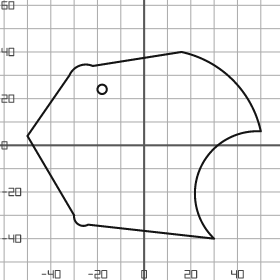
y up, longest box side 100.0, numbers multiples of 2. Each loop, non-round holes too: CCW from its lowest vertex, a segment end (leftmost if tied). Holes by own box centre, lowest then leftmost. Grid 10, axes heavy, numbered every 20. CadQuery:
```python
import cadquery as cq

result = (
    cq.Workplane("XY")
    .moveTo(30.0, -40.0)
    .threePointArc((24.0, -10.0), (50.0, 6.0))
    .threePointArc((38.0, 28.0), (16.0, 40.0))
    .lineTo(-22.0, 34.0)
    .threePointArc((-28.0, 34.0), (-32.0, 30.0))
    .lineTo(-50.0, 4.0)
    .lineTo(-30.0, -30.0)
    .threePointArc((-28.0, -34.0), (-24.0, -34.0))
    .close()
    .moveTo(-18.0, 24.0)
    .circle(2.0)
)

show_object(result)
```